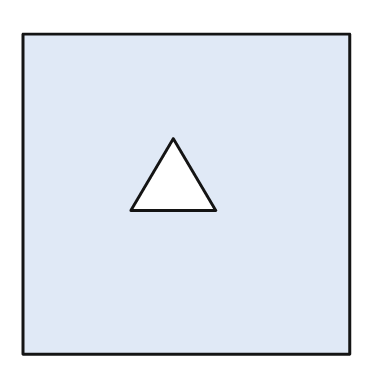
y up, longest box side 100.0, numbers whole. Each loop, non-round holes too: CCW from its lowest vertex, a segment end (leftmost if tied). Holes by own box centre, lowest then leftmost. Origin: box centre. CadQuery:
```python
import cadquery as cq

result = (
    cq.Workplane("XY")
    .moveTo(-50.0, -49.0)
    .lineTo(50.0, -49.0)
    .lineTo(50.0, 49.0)
    .lineTo(-50.0, 49.0)
    .close()
    .moveTo(-17.0, -5.0)
    .lineTo(9.0, -5.0)
    .lineTo(-4.0, 17.0)
    .close()
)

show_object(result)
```